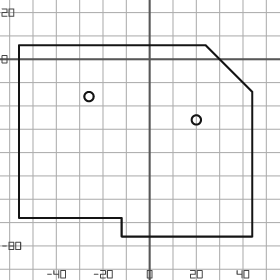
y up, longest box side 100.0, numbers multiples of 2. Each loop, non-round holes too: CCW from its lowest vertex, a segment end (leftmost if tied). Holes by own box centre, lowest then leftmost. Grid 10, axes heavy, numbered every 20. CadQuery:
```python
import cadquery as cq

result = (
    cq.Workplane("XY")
    .moveTo(-12.0, -76.0)
    .lineTo(44.0, -76.0)
    .lineTo(44.0, -14.0)
    .lineTo(24.0, 6.0)
    .lineTo(-56.0, 6.0)
    .lineTo(-56.0, -68.0)
    .lineTo(-12.0, -68.0)
    .close()
    .moveTo(20.0, -26.0)
    .circle(2.0)
    .moveTo(-26.0, -16.0)
    .circle(2.0)
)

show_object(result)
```